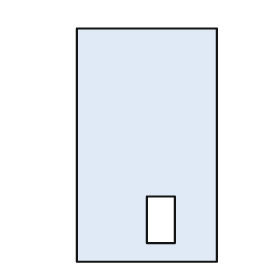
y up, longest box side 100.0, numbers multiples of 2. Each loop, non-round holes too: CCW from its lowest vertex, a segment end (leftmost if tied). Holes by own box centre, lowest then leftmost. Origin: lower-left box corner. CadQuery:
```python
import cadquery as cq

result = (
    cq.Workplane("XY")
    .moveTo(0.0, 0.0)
    .lineTo(60.0, 0.0)
    .lineTo(60.0, 100.0)
    .lineTo(0.0, 100.0)
    .close()
    .moveTo(30.0, 8.0)
    .lineTo(42.0, 8.0)
    .lineTo(42.0, 28.0)
    .lineTo(30.0, 28.0)
    .close()
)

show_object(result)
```